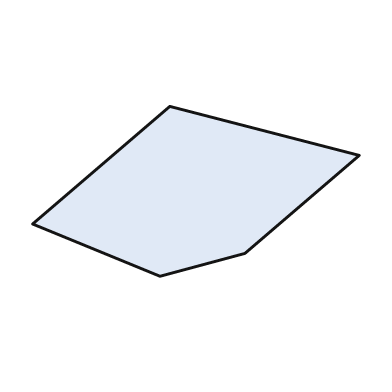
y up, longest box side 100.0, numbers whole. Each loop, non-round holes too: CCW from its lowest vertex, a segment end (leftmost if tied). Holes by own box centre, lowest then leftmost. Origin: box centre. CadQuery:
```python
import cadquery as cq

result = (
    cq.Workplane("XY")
    .moveTo(-11.0, -26.0)
    .lineTo(15.0, -19.0)
    .lineTo(50.0, 11.0)
    .lineTo(-8.0, 26.0)
    .lineTo(-50.0, -10.0)
    .close()
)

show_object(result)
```